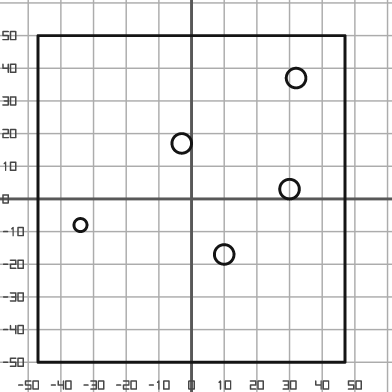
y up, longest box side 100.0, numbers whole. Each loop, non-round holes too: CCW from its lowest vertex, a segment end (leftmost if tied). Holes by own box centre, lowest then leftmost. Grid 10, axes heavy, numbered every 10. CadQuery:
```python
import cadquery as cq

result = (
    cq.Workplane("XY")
    .moveTo(-47.0, -50.0)
    .lineTo(47.0, -50.0)
    .lineTo(47.0, 50.0)
    .lineTo(-47.0, 50.0)
    .close()
    .moveTo(10.0, -17.0)
    .circle(3.0)
    .moveTo(-34.0, -8.0)
    .circle(2.0)
    .moveTo(30.0, 3.0)
    .circle(3.0)
    .moveTo(-3.0, 17.0)
    .circle(3.0)
    .moveTo(32.0, 37.0)
    .circle(3.0)
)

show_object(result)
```